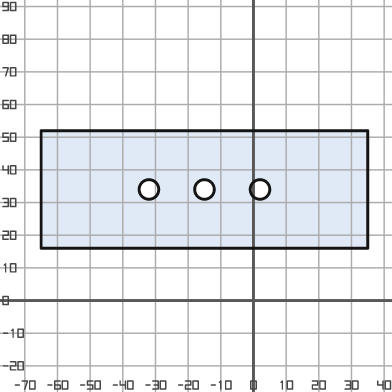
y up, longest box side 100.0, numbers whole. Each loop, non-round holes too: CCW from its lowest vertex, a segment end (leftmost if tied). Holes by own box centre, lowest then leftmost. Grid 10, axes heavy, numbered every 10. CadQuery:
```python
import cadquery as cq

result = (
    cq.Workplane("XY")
    .moveTo(-65.0, 16.0)
    .lineTo(35.0, 16.0)
    .lineTo(35.0, 52.0)
    .lineTo(-65.0, 52.0)
    .close()
    .moveTo(-32.0, 34.0)
    .circle(3.0)
    .moveTo(-15.0, 34.0)
    .circle(3.0)
    .moveTo(2.0, 34.0)
    .circle(3.0)
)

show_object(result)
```